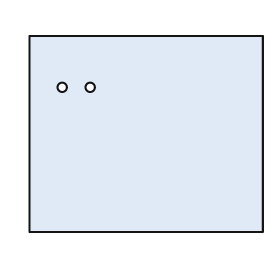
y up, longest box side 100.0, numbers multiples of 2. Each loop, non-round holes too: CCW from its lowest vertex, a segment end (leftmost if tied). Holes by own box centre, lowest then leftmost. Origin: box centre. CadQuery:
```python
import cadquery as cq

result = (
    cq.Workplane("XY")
    .moveTo(-50.0, -42.0)
    .lineTo(50.0, -42.0)
    .lineTo(50.0, 42.0)
    .lineTo(-50.0, 42.0)
    .close()
    .moveTo(-36.0, 20.0)
    .circle(2.0)
    .moveTo(-24.0, 20.0)
    .circle(2.0)
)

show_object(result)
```